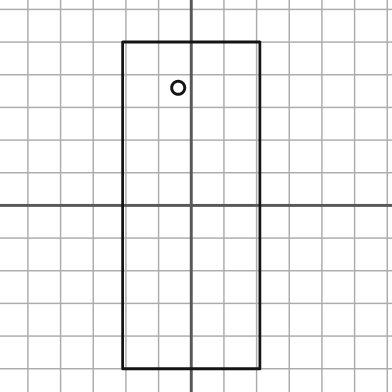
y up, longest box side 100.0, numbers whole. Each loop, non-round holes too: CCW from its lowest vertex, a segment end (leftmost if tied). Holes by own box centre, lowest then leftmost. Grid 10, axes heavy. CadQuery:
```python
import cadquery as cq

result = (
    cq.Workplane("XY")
    .moveTo(-21.0, -50.0)
    .lineTo(21.0, -50.0)
    .lineTo(21.0, 50.0)
    .lineTo(-21.0, 50.0)
    .close()
    .moveTo(-4.0, 36.0)
    .circle(2.0)
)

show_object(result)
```